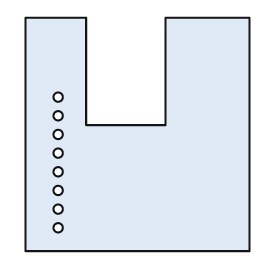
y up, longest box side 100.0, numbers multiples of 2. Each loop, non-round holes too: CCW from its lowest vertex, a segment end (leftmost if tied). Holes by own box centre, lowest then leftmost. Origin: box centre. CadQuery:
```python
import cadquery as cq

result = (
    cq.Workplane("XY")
    .moveTo(-48.0, -50.0)
    .lineTo(48.0, -50.0)
    .lineTo(48.0, 50.0)
    .lineTo(12.0, 50.0)
    .lineTo(12.0, 4.0)
    .lineTo(-22.0, 4.0)
    .lineTo(-22.0, 50.0)
    .lineTo(-48.0, 50.0)
    .close()
    .moveTo(-34.0, -40.0)
    .circle(2.0)
    .moveTo(-34.0, -32.0)
    .circle(2.0)
    .moveTo(-34.0, -24.0)
    .circle(2.0)
    .moveTo(-34.0, -16.0)
    .circle(2.0)
    .moveTo(-34.0, -8.0)
    .circle(2.0)
    .moveTo(-34.0, 0.0)
    .circle(2.0)
    .moveTo(-34.0, 8.0)
    .circle(2.0)
    .moveTo(-34.0, 16.0)
    .circle(2.0)
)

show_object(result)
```